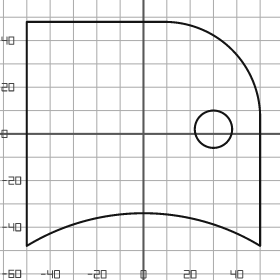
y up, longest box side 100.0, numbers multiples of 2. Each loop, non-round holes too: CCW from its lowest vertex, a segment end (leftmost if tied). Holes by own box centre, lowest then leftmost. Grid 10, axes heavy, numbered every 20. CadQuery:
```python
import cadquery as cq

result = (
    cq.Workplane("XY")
    .moveTo(-50.0, -48.0)
    .threePointArc((0.0, -34.0), (50.0, -48.0))
    .lineTo(50.0, 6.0)
    .threePointArc((38.0, 36.0), (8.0, 48.0))
    .lineTo(-50.0, 48.0)
    .close()
    .moveTo(30.0, 2.0)
    .circle(8.0)
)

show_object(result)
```